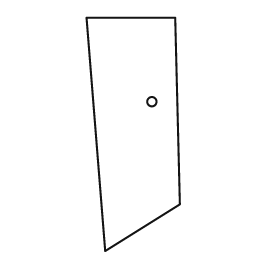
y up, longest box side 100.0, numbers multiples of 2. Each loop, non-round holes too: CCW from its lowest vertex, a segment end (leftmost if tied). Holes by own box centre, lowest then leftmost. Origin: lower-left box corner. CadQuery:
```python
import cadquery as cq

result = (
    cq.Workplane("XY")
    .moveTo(8.0, 0.0)
    .lineTo(40.0, 20.0)
    .lineTo(38.0, 100.0)
    .lineTo(0.0, 100.0)
    .close()
    .moveTo(28.0, 64.0)
    .circle(2.0)
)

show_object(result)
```